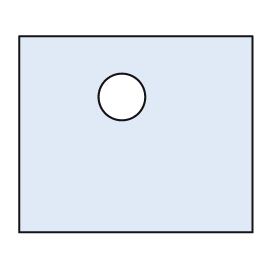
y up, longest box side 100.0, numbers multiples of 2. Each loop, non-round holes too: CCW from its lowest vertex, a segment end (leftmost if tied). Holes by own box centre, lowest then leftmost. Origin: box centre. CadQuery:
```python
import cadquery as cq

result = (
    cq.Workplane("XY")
    .moveTo(-50.0, -42.0)
    .lineTo(50.0, -42.0)
    .lineTo(50.0, 42.0)
    .lineTo(-50.0, 42.0)
    .close()
    .moveTo(-6.0, 16.0)
    .circle(10.0)
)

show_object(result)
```